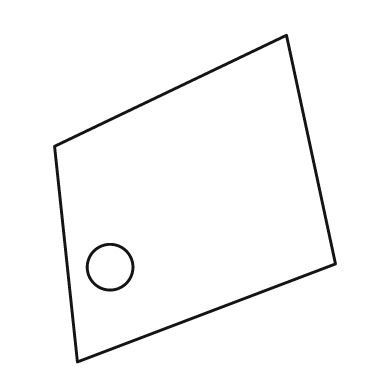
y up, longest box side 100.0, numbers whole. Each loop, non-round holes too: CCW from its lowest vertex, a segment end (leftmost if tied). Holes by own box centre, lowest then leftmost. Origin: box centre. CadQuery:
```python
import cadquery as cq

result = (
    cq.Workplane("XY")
    .moveTo(-36.0, -50.0)
    .lineTo(43.0, -20.0)
    .lineTo(28.0, 50.0)
    .lineTo(-43.0, 16.0)
    .close()
    .moveTo(-26.0, -21.0)
    .circle(7.0)
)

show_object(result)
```